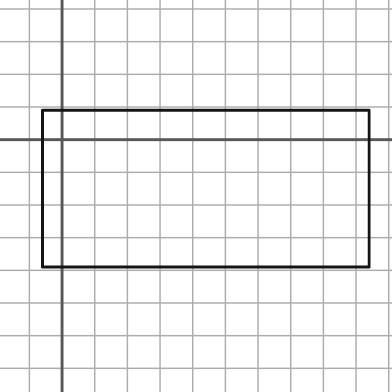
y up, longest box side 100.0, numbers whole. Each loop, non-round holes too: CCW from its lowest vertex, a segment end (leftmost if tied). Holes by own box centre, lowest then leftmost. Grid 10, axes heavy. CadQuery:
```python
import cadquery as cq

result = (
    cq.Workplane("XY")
    .moveTo(-6.0, -39.0)
    .lineTo(94.0, -39.0)
    .lineTo(94.0, 9.0)
    .lineTo(-6.0, 9.0)
    .close()
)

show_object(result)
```